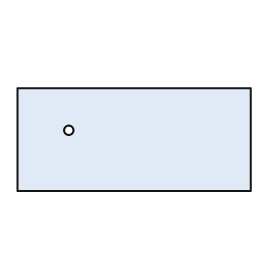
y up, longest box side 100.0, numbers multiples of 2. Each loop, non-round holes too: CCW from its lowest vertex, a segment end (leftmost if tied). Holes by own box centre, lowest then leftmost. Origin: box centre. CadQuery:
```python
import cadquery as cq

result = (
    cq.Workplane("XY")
    .moveTo(-50.0, -22.0)
    .lineTo(50.0, -22.0)
    .lineTo(50.0, 22.0)
    .lineTo(-50.0, 22.0)
    .close()
    .moveTo(-28.0, 4.0)
    .circle(2.0)
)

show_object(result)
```